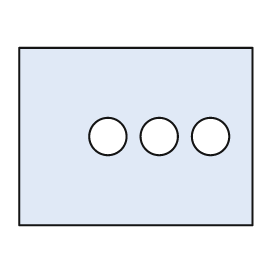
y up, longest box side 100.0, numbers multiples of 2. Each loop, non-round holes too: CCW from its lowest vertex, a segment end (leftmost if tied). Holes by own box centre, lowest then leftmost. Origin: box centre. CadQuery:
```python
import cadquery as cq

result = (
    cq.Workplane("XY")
    .moveTo(-50.0, -38.0)
    .lineTo(50.0, -38.0)
    .lineTo(50.0, 38.0)
    .lineTo(-50.0, 38.0)
    .close()
    .moveTo(-12.0, 0.0)
    .circle(8.0)
    .moveTo(10.0, 0.0)
    .circle(8.0)
    .moveTo(32.0, 0.0)
    .circle(8.0)
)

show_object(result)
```